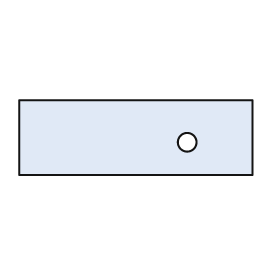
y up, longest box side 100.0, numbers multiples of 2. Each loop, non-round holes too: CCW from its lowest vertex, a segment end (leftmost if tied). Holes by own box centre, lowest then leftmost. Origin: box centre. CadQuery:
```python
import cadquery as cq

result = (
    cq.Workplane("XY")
    .moveTo(-50.0, -16.0)
    .lineTo(50.0, -16.0)
    .lineTo(50.0, 16.0)
    .lineTo(-50.0, 16.0)
    .close()
    .moveTo(22.0, -2.0)
    .circle(4.0)
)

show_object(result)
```